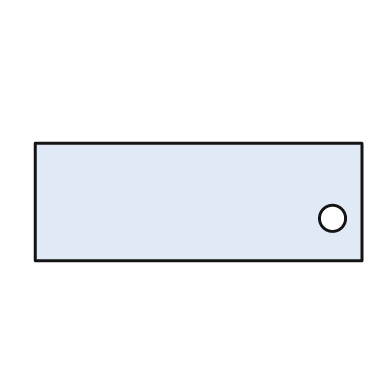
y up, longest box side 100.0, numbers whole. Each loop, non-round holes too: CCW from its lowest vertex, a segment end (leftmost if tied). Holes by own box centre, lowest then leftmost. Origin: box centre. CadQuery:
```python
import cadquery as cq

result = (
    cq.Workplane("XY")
    .moveTo(-50.0, -18.0)
    .lineTo(50.0, -18.0)
    .lineTo(50.0, 18.0)
    .lineTo(-50.0, 18.0)
    .close()
    .moveTo(41.0, -5.0)
    .circle(4.0)
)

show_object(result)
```